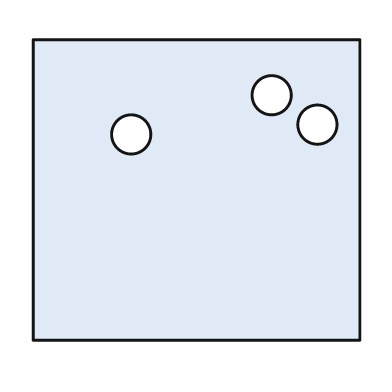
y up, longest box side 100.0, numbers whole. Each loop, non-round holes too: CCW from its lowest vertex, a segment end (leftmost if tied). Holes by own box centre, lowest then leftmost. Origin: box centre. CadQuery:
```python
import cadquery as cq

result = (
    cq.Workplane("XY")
    .moveTo(-50.0, -46.0)
    .lineTo(50.0, -46.0)
    .lineTo(50.0, 46.0)
    .lineTo(-50.0, 46.0)
    .close()
    .moveTo(-20.0, 17.0)
    .circle(6.0)
    .moveTo(37.0, 20.0)
    .circle(6.0)
    .moveTo(23.0, 29.0)
    .circle(6.0)
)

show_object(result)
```